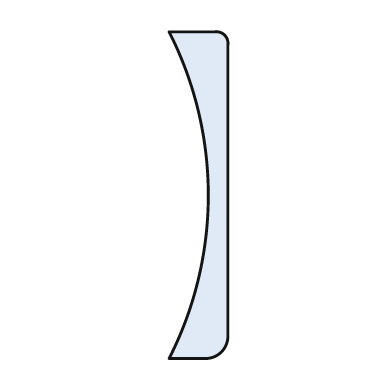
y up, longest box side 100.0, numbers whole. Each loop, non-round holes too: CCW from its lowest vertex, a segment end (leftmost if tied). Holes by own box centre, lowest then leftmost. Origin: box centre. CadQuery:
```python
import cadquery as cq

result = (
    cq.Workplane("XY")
    .moveTo(-9.0, -50.0)
    .lineTo(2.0, -50.0)
    .threePointArc((7.0, -48.0), (9.0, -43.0))
    .lineTo(9.0, 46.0)
    .threePointArc((8.0, 49.0), (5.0, 50.0))
    .lineTo(-9.0, 50.0)
    .threePointArc((3.0, 0.0), (-9.0, -50.0))
    .close()
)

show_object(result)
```